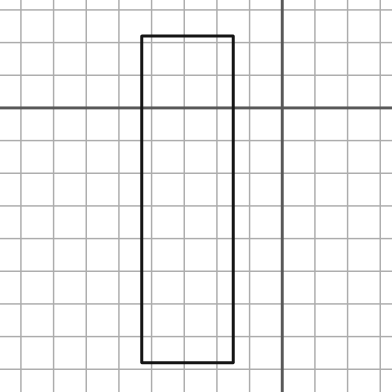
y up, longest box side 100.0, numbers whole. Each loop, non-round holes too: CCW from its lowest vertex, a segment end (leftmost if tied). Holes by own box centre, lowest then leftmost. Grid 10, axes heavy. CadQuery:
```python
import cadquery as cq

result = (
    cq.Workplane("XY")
    .moveTo(-43.0, -78.0)
    .lineTo(-15.0, -78.0)
    .lineTo(-15.0, 22.0)
    .lineTo(-43.0, 22.0)
    .close()
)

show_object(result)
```